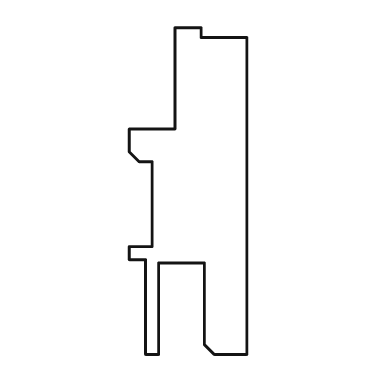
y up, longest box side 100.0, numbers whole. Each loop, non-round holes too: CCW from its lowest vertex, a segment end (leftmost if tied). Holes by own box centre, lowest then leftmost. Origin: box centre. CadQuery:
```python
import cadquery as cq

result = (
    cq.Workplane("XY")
    .moveTo(-13.0, -50.0)
    .lineTo(-9.0, -50.0)
    .lineTo(-9.0, -22.0)
    .lineTo(5.0, -22.0)
    .lineTo(5.0, -47.0)
    .lineTo(8.0, -50.0)
    .lineTo(18.0, -50.0)
    .lineTo(18.0, 47.0)
    .lineTo(4.0, 47.0)
    .lineTo(4.0, 50.0)
    .lineTo(-4.0, 50.0)
    .lineTo(-4.0, 19.0)
    .lineTo(-18.0, 19.0)
    .lineTo(-18.0, 12.0)
    .lineTo(-15.0, 9.0)
    .lineTo(-11.0, 9.0)
    .lineTo(-11.0, -17.0)
    .lineTo(-18.0, -17.0)
    .lineTo(-18.0, -21.0)
    .lineTo(-13.0, -21.0)
    .close()
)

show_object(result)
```